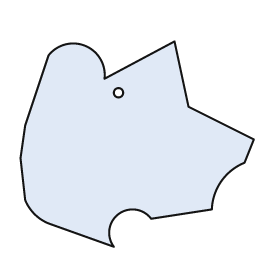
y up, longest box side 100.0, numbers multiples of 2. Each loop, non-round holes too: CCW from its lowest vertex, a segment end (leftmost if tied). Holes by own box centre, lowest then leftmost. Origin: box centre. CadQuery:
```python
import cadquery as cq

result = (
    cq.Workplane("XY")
    .moveTo(-10.0, -44.0)
    .threePointArc((-8.0, -30.0), (6.0, -32.0))
    .lineTo(32.0, -28.0)
    .threePointArc((36.0, -16.0), (46.0, -8.0))
    .lineTo(50.0, 2.0)
    .lineTo(22.0, 16.0)
    .lineTo(16.0, 44.0)
    .lineTo(-14.0, 28.0)
    .threePointArc((-22.0, 42.0), (-38.0, 38.0))
    .lineTo(-48.0, 8.0)
    .lineTo(-50.0, -6.0)
    .lineTo(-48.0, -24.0)
    .threePointArc((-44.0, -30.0), (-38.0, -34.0))
    .close()
    .moveTo(-8.0, 22.0)
    .circle(2.0)
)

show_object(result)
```